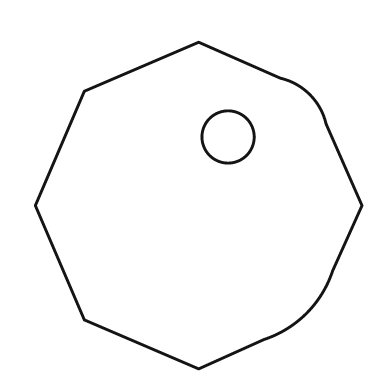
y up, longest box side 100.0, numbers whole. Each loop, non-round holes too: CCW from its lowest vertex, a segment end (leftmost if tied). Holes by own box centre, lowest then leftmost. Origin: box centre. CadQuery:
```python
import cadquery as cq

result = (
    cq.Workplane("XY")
    .moveTo(0.0, -50.0)
    .lineTo(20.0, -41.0)
    .threePointArc((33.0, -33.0), (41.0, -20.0))
    .lineTo(50.0, 0.0)
    .lineTo(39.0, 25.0)
    .threePointArc((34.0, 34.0), (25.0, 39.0))
    .lineTo(0.0, 50.0)
    .lineTo(-35.0, 35.0)
    .lineTo(-50.0, 0.0)
    .lineTo(-35.0, -35.0)
    .close()
    .moveTo(9.0, 21.0)
    .circle(8.0)
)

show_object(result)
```